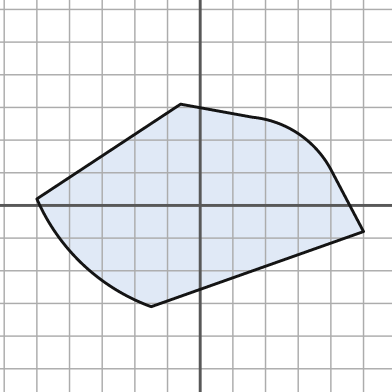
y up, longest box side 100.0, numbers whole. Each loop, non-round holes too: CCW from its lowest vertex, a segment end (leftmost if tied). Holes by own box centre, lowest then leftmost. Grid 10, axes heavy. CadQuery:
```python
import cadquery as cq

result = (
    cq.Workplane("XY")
    .moveTo(-15.0, -31.0)
    .lineTo(50.0, -8.0)
    .lineTo(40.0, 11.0)
    .threePointArc((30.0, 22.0), (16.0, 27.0))
    .lineTo(-6.0, 31.0)
    .lineTo(-50.0, 2.0)
    .threePointArc((-36.0, -18.0), (-15.0, -31.0))
    .close()
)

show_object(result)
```